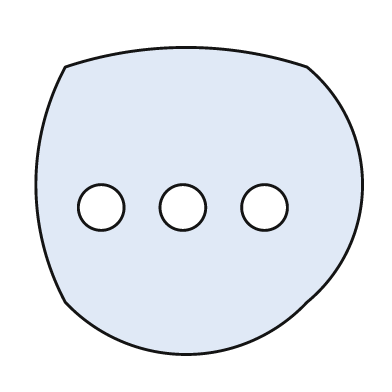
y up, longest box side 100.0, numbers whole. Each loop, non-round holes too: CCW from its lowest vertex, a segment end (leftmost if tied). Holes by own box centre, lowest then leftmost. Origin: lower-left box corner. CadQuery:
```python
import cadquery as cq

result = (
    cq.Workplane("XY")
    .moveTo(9.0, 16.0)
    .threePointArc((46.0, 0.0), (83.0, 16.0))
    .threePointArc((100.0, 52.0), (83.0, 88.0))
    .threePointArc((46.0, 94.0), (9.0, 88.0))
    .threePointArc((0.0, 52.0), (9.0, 16.0))
    .close()
    .moveTo(20.0, 45.0)
    .circle(7.0)
    .moveTo(45.0, 45.0)
    .circle(7.0)
    .moveTo(70.0, 45.0)
    .circle(7.0)
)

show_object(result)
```